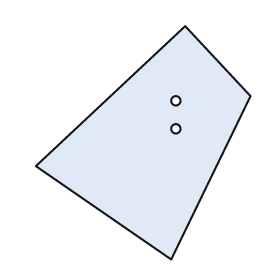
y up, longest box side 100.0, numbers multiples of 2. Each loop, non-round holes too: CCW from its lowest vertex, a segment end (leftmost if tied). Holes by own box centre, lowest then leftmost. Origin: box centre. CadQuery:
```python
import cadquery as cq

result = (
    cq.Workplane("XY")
    .moveTo(12.0, -50.0)
    .lineTo(46.0, 20.0)
    .lineTo(18.0, 50.0)
    .lineTo(-46.0, -10.0)
    .close()
    .moveTo(14.0, 6.0)
    .circle(2.0)
    .moveTo(14.0, 18.0)
    .circle(2.0)
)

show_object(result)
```